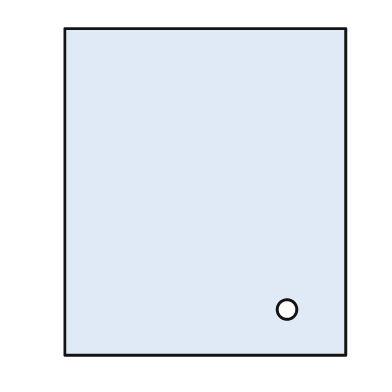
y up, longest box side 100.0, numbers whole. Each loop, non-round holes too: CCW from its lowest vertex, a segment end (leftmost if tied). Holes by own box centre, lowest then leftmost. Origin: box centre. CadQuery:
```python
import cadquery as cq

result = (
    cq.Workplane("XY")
    .moveTo(-43.0, -50.0)
    .lineTo(43.0, -50.0)
    .lineTo(43.0, 50.0)
    .lineTo(-43.0, 50.0)
    .close()
    .moveTo(25.0, -36.0)
    .circle(3.0)
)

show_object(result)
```